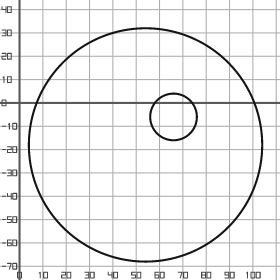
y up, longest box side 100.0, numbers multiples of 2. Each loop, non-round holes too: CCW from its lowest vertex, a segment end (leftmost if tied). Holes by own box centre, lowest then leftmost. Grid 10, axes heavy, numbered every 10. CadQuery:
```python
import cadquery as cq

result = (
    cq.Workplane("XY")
    .moveTo(54.0, -18.0)
    .circle(50.0)
    .moveTo(66.0, -6.0)
    .circle(10.0)
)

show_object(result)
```